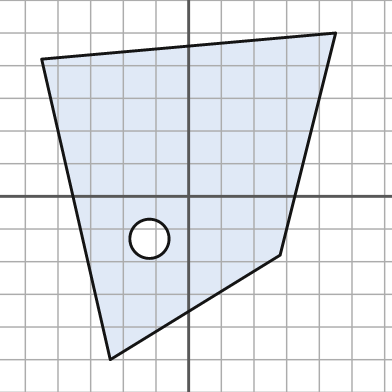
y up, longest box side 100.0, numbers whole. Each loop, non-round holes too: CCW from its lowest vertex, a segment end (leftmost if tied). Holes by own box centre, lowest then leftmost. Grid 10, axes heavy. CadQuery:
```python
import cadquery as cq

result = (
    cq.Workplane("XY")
    .moveTo(-24.0, -50.0)
    .lineTo(28.0, -18.0)
    .lineTo(45.0, 50.0)
    .lineTo(-45.0, 42.0)
    .close()
    .moveTo(-12.0, -13.0)
    .circle(6.0)
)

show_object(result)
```